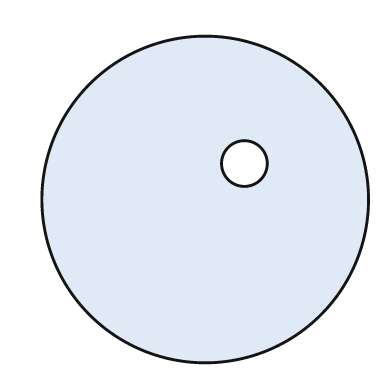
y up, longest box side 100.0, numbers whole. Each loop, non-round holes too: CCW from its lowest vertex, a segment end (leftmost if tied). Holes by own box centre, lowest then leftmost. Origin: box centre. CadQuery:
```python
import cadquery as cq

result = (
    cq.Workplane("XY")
    .moveTo(0.0, 0.0)
    .circle(50.0)
    .moveTo(12.0, 11.0)
    .circle(7.0)
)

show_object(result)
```